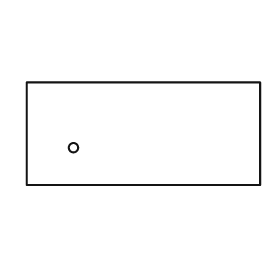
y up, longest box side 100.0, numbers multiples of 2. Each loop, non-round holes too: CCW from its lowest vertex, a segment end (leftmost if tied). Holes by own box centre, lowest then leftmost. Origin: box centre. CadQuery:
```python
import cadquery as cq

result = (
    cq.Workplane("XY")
    .moveTo(-50.0, -22.0)
    .lineTo(50.0, -22.0)
    .lineTo(50.0, 22.0)
    .lineTo(-50.0, 22.0)
    .close()
    .moveTo(-30.0, -6.0)
    .circle(2.0)
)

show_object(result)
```